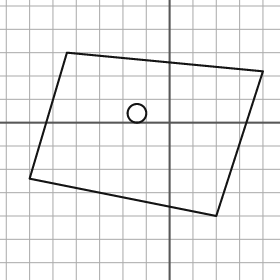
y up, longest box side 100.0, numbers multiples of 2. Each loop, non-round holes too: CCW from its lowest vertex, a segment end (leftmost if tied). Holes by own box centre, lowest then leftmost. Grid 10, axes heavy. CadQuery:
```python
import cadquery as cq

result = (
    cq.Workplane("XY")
    .moveTo(20.0, -40.0)
    .lineTo(40.0, 22.0)
    .lineTo(-44.0, 30.0)
    .lineTo(-60.0, -24.0)
    .close()
    .moveTo(-14.0, 4.0)
    .circle(4.0)
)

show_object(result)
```